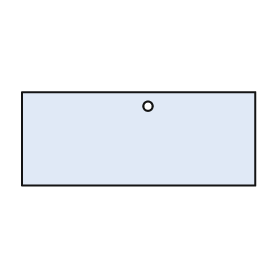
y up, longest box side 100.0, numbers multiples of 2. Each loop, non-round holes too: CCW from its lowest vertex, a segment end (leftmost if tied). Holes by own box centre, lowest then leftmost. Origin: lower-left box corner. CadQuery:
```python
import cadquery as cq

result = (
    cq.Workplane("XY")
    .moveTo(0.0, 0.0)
    .lineTo(100.0, 0.0)
    .lineTo(100.0, 40.0)
    .lineTo(0.0, 40.0)
    .close()
    .moveTo(54.0, 34.0)
    .circle(2.0)
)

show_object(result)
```